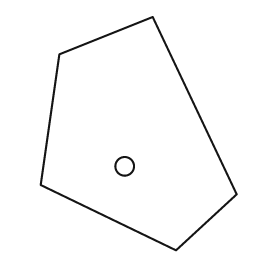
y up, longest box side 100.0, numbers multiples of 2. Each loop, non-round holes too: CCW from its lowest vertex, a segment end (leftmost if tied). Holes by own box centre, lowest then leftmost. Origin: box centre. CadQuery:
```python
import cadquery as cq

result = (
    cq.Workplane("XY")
    .moveTo(16.0, -50.0)
    .lineTo(42.0, -26.0)
    .lineTo(6.0, 50.0)
    .lineTo(-34.0, 34.0)
    .lineTo(-42.0, -22.0)
    .close()
    .moveTo(-6.0, -14.0)
    .circle(4.0)
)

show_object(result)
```